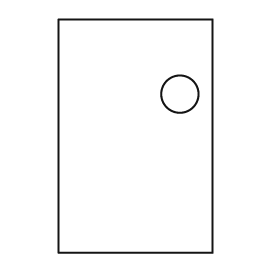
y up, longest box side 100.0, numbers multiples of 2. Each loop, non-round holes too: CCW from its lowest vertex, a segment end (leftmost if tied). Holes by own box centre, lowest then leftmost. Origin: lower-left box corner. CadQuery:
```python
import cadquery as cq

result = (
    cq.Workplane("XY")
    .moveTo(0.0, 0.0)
    .lineTo(66.0, 0.0)
    .lineTo(66.0, 100.0)
    .lineTo(0.0, 100.0)
    .close()
    .moveTo(52.0, 68.0)
    .circle(8.0)
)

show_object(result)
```